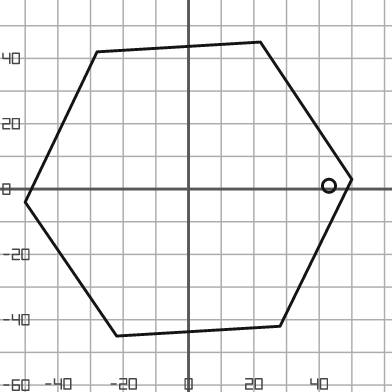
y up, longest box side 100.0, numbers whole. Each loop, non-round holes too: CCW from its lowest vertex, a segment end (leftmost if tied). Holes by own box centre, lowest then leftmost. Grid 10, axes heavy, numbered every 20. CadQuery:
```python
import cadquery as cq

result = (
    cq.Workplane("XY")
    .moveTo(-22.0, -45.0)
    .lineTo(28.0, -42.0)
    .lineTo(50.0, 3.0)
    .lineTo(22.0, 45.0)
    .lineTo(-28.0, 42.0)
    .lineTo(-50.0, -4.0)
    .close()
    .moveTo(43.0, 1.0)
    .circle(2.0)
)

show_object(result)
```